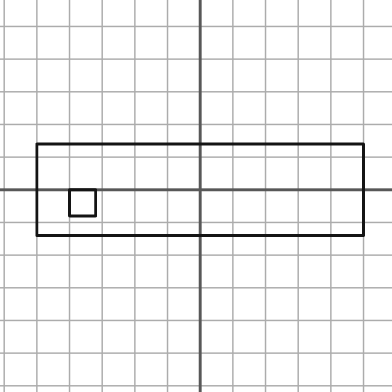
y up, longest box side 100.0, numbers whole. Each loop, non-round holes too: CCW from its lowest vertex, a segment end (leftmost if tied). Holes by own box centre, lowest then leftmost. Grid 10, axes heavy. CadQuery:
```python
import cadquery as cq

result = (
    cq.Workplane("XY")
    .moveTo(-50.0, -14.0)
    .lineTo(50.0, -14.0)
    .lineTo(50.0, 14.0)
    .lineTo(-50.0, 14.0)
    .close()
    .moveTo(-40.0, -8.0)
    .lineTo(-32.0, -8.0)
    .lineTo(-32.0, 0.0)
    .lineTo(-40.0, 0.0)
    .close()
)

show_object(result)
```